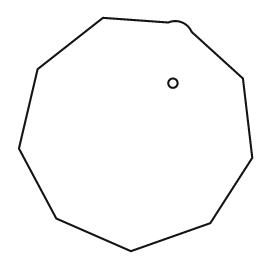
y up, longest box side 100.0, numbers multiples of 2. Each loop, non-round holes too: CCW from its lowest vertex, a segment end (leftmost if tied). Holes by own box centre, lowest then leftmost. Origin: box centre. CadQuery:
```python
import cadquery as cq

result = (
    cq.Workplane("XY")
    .moveTo(-2.0, -50.0)
    .lineTo(32.0, -38.0)
    .lineTo(50.0, -10.0)
    .lineTo(46.0, 24.0)
    .lineTo(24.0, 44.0)
    .threePointArc((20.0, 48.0), (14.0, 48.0))
    .lineTo(-14.0, 50.0)
    .lineTo(-42.0, 28.0)
    .lineTo(-50.0, -6.0)
    .lineTo(-34.0, -36.0)
    .close()
    .moveTo(16.0, 22.0)
    .circle(2.0)
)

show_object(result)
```